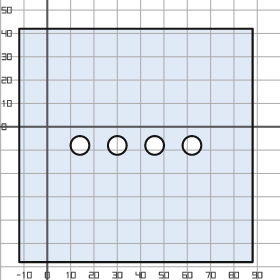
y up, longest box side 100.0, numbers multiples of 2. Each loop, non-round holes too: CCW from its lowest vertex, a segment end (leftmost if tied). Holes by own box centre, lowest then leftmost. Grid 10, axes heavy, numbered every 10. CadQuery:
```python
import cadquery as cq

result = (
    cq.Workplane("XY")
    .moveTo(-12.0, -58.0)
    .lineTo(88.0, -58.0)
    .lineTo(88.0, 42.0)
    .lineTo(-12.0, 42.0)
    .close()
    .moveTo(14.0, -8.0)
    .circle(4.0)
    .moveTo(30.0, -8.0)
    .circle(4.0)
    .moveTo(46.0, -8.0)
    .circle(4.0)
    .moveTo(62.0, -8.0)
    .circle(4.0)
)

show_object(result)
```